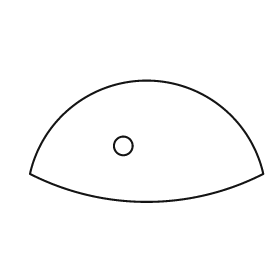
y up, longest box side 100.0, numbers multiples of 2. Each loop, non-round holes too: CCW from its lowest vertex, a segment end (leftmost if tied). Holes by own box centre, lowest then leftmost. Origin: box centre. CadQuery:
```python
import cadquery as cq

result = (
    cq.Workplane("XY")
    .moveTo(-50.0, -14.0)
    .threePointArc((0.0, -26.0), (50.0, -14.0))
    .threePointArc((0.0, 26.0), (-50.0, -14.0))
    .close()
    .moveTo(-10.0, -2.0)
    .circle(4.0)
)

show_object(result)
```